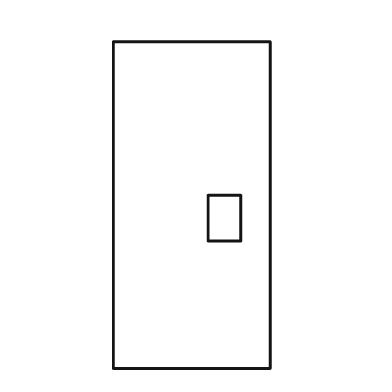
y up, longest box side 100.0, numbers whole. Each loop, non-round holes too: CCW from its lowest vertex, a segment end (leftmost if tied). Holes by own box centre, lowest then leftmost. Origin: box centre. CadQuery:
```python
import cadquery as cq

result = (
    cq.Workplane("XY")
    .moveTo(-24.0, -50.0)
    .lineTo(24.0, -50.0)
    .lineTo(24.0, 50.0)
    .lineTo(-24.0, 50.0)
    .close()
    .moveTo(5.0, -11.0)
    .lineTo(15.0, -11.0)
    .lineTo(15.0, 3.0)
    .lineTo(5.0, 3.0)
    .close()
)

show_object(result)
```